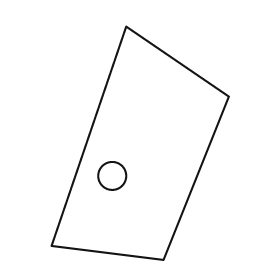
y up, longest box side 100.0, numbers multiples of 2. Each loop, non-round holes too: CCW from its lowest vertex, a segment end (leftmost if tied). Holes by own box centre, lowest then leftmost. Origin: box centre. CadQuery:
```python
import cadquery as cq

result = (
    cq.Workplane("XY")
    .moveTo(10.0, -50.0)
    .lineTo(38.0, 20.0)
    .lineTo(-6.0, 50.0)
    .lineTo(-38.0, -44.0)
    .close()
    .moveTo(-12.0, -14.0)
    .circle(6.0)
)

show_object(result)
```